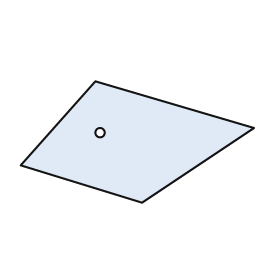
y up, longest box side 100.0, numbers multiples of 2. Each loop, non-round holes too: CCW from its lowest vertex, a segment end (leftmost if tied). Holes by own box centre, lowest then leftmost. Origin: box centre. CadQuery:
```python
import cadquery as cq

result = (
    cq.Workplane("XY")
    .moveTo(2.0, -26.0)
    .lineTo(50.0, 6.0)
    .lineTo(-18.0, 26.0)
    .lineTo(-50.0, -10.0)
    .close()
    .moveTo(-16.0, 4.0)
    .circle(2.0)
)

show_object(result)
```